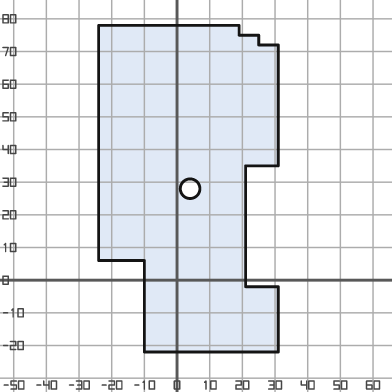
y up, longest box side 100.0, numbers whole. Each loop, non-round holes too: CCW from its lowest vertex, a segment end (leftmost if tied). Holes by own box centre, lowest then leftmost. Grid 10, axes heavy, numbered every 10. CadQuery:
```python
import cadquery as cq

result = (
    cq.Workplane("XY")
    .moveTo(-10.0, -22.0)
    .lineTo(31.0, -22.0)
    .lineTo(31.0, -2.0)
    .lineTo(21.0, -2.0)
    .lineTo(21.0, 35.0)
    .lineTo(31.0, 35.0)
    .lineTo(31.0, 72.0)
    .lineTo(25.0, 72.0)
    .lineTo(25.0, 75.0)
    .lineTo(19.0, 75.0)
    .lineTo(19.0, 78.0)
    .lineTo(-24.0, 78.0)
    .lineTo(-24.0, 6.0)
    .lineTo(-10.0, 6.0)
    .close()
    .moveTo(4.0, 28.0)
    .circle(3.0)
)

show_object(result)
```